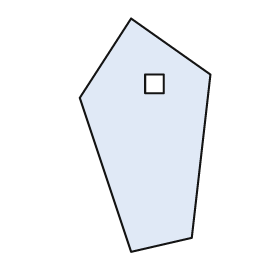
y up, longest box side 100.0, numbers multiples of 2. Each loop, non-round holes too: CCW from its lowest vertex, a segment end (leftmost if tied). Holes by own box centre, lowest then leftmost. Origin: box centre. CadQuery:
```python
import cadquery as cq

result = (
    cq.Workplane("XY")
    .moveTo(-6.0, -50.0)
    .lineTo(20.0, -44.0)
    .lineTo(28.0, 26.0)
    .lineTo(-6.0, 50.0)
    .lineTo(-28.0, 16.0)
    .close()
    .moveTo(0.0, 18.0)
    .lineTo(8.0, 18.0)
    .lineTo(8.0, 26.0)
    .lineTo(0.0, 26.0)
    .close()
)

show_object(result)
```